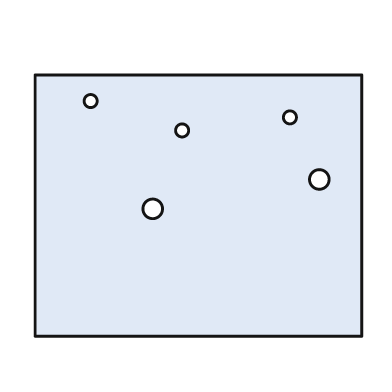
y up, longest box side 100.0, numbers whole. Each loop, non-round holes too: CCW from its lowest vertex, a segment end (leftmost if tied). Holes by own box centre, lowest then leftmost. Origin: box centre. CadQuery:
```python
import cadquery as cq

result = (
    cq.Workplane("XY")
    .moveTo(-50.0, -40.0)
    .lineTo(50.0, -40.0)
    .lineTo(50.0, 40.0)
    .lineTo(-50.0, 40.0)
    .close()
    .moveTo(-14.0, -1.0)
    .circle(3.0)
    .moveTo(37.0, 8.0)
    .circle(3.0)
    .moveTo(-5.0, 23.0)
    .circle(2.0)
    .moveTo(28.0, 27.0)
    .circle(2.0)
    .moveTo(-33.0, 32.0)
    .circle(2.0)
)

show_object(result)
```